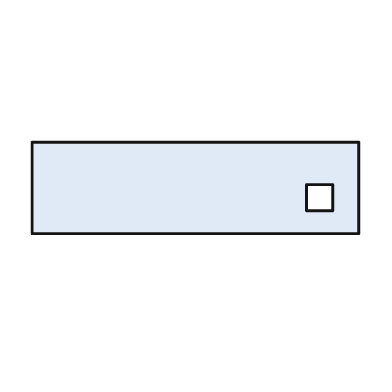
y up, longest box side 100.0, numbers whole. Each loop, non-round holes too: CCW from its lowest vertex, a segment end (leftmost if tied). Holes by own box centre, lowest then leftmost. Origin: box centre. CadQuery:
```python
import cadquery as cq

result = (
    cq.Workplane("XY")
    .moveTo(-50.0, -14.0)
    .lineTo(50.0, -14.0)
    .lineTo(50.0, 14.0)
    .lineTo(-50.0, 14.0)
    .close()
    .moveTo(34.0, -7.0)
    .lineTo(42.0, -7.0)
    .lineTo(42.0, 1.0)
    .lineTo(34.0, 1.0)
    .close()
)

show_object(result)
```